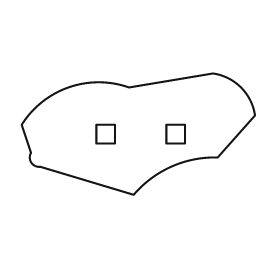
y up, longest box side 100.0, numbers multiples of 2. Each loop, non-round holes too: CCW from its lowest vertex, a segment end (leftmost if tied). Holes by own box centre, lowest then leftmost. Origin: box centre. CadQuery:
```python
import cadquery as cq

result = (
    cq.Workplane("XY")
    .moveTo(-2.0, -26.0)
    .threePointArc((14.0, -14.0), (34.0, -10.0))
    .lineTo(50.0, 8.0)
    .threePointArc((44.0, 20.0), (32.0, 26.0))
    .lineTo(-4.0, 20.0)
    .threePointArc((-30.0, 20.0), (-50.0, 4.0))
    .lineTo(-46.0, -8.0)
    .threePointArc((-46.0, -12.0), (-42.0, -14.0))
    .close()
    .moveTo(-18.0, -4.0)
    .lineTo(-10.0, -4.0)
    .lineTo(-10.0, 4.0)
    .lineTo(-18.0, 4.0)
    .close()
    .moveTo(12.0, -4.0)
    .lineTo(20.0, -4.0)
    .lineTo(20.0, 4.0)
    .lineTo(12.0, 4.0)
    .close()
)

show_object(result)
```